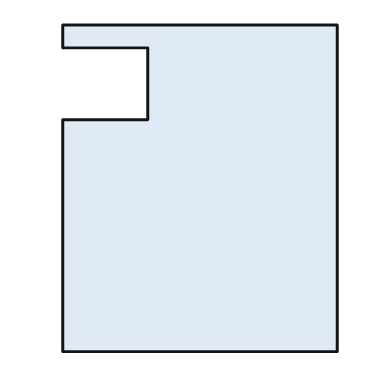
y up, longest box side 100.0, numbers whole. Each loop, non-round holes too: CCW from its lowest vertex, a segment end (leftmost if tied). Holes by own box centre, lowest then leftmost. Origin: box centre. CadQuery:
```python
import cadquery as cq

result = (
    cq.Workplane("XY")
    .moveTo(-42.0, -50.0)
    .lineTo(42.0, -50.0)
    .lineTo(42.0, 50.0)
    .lineTo(-42.0, 50.0)
    .lineTo(-42.0, 43.0)
    .lineTo(-16.0, 43.0)
    .lineTo(-16.0, 21.0)
    .lineTo(-42.0, 21.0)
    .close()
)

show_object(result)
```